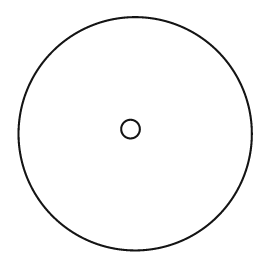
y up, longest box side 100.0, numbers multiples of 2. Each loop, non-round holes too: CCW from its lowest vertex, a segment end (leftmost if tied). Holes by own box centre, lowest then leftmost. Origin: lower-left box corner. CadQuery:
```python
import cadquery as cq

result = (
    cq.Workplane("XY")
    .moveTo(50.0, 50.0)
    .circle(50.0)
    .moveTo(48.0, 52.0)
    .circle(4.0)
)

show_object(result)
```